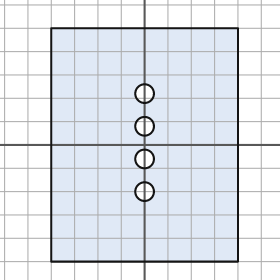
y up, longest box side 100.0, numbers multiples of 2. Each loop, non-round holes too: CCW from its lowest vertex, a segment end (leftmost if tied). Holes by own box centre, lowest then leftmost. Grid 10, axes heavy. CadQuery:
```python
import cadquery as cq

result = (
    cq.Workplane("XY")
    .moveTo(-40.0, -50.0)
    .lineTo(40.0, -50.0)
    .lineTo(40.0, 50.0)
    .lineTo(-40.0, 50.0)
    .close()
    .moveTo(0.0, -20.0)
    .circle(4.0)
    .moveTo(0.0, -6.0)
    .circle(4.0)
    .moveTo(0.0, 8.0)
    .circle(4.0)
    .moveTo(0.0, 22.0)
    .circle(4.0)
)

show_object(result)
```